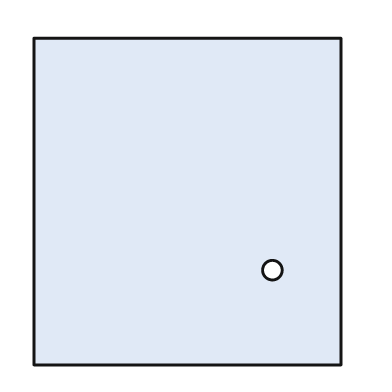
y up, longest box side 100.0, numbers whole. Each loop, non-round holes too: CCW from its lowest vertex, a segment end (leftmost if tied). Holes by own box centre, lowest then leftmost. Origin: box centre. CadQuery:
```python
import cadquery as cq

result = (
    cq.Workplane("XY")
    .moveTo(-47.0, -50.0)
    .lineTo(47.0, -50.0)
    .lineTo(47.0, 50.0)
    .lineTo(-47.0, 50.0)
    .close()
    .moveTo(26.0, -21.0)
    .circle(3.0)
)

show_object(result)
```